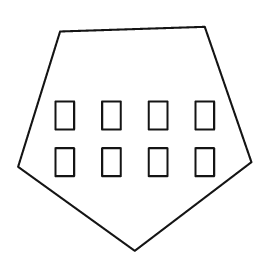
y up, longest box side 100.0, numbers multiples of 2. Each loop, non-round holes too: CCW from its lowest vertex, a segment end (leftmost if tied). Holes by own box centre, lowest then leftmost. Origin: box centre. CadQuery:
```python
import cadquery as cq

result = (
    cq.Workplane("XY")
    .moveTo(0.0, -48.0)
    .lineTo(50.0, -10.0)
    .lineTo(30.0, 48.0)
    .lineTo(-32.0, 46.0)
    .lineTo(-50.0, -12.0)
    .close()
    .moveTo(-34.0, -16.0)
    .lineTo(-26.0, -16.0)
    .lineTo(-26.0, -4.0)
    .lineTo(-34.0, -4.0)
    .close()
    .moveTo(-14.0, -16.0)
    .lineTo(-6.0, -16.0)
    .lineTo(-6.0, -4.0)
    .lineTo(-14.0, -4.0)
    .close()
    .moveTo(6.0, -16.0)
    .lineTo(14.0, -16.0)
    .lineTo(14.0, -4.0)
    .lineTo(6.0, -4.0)
    .close()
    .moveTo(26.0, -16.0)
    .lineTo(34.0, -16.0)
    .lineTo(34.0, -4.0)
    .lineTo(26.0, -4.0)
    .close()
    .moveTo(-34.0, 4.0)
    .lineTo(-26.0, 4.0)
    .lineTo(-26.0, 16.0)
    .lineTo(-34.0, 16.0)
    .close()
    .moveTo(-14.0, 4.0)
    .lineTo(-6.0, 4.0)
    .lineTo(-6.0, 16.0)
    .lineTo(-14.0, 16.0)
    .close()
    .moveTo(6.0, 4.0)
    .lineTo(14.0, 4.0)
    .lineTo(14.0, 16.0)
    .lineTo(6.0, 16.0)
    .close()
    .moveTo(26.0, 4.0)
    .lineTo(34.0, 4.0)
    .lineTo(34.0, 16.0)
    .lineTo(26.0, 16.0)
    .close()
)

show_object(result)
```